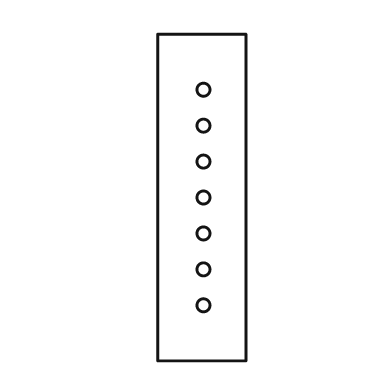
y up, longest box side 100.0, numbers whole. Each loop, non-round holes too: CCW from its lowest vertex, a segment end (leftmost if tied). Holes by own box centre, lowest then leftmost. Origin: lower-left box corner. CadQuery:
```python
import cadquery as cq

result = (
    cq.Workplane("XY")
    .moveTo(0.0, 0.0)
    .lineTo(27.0, 0.0)
    .lineTo(27.0, 100.0)
    .lineTo(0.0, 100.0)
    .close()
    .moveTo(14.0, 17.0)
    .circle(2.0)
    .moveTo(14.0, 28.0)
    .circle(2.0)
    .moveTo(14.0, 39.0)
    .circle(2.0)
    .moveTo(14.0, 50.0)
    .circle(2.0)
    .moveTo(14.0, 61.0)
    .circle(2.0)
    .moveTo(14.0, 72.0)
    .circle(2.0)
    .moveTo(14.0, 83.0)
    .circle(2.0)
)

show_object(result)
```